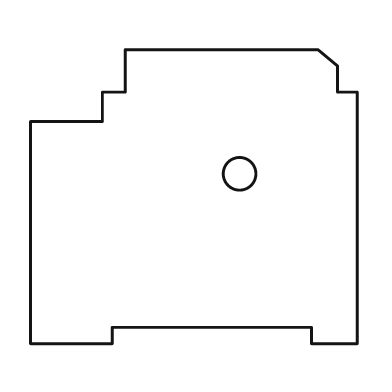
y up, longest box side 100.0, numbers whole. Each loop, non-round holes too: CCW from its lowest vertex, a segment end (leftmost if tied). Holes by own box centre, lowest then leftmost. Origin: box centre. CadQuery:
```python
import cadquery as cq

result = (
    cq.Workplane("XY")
    .moveTo(-50.0, -45.0)
    .lineTo(-25.0, -45.0)
    .lineTo(-25.0, -40.0)
    .lineTo(36.0, -40.0)
    .lineTo(36.0, -45.0)
    .lineTo(50.0, -45.0)
    .lineTo(50.0, 32.0)
    .lineTo(44.0, 32.0)
    .lineTo(44.0, 40.0)
    .lineTo(38.0, 45.0)
    .lineTo(-21.0, 45.0)
    .lineTo(-21.0, 32.0)
    .lineTo(-28.0, 32.0)
    .lineTo(-28.0, 23.0)
    .lineTo(-50.0, 23.0)
    .close()
    .moveTo(14.0, 7.0)
    .circle(5.0)
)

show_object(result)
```